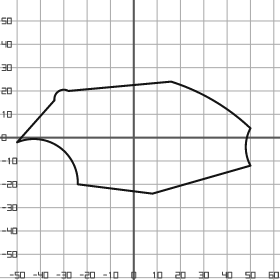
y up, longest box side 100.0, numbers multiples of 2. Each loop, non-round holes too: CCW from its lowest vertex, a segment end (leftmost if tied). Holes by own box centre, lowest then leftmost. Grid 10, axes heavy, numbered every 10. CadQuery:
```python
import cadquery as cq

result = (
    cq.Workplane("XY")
    .moveTo(8.0, -24.0)
    .lineTo(50.0, -12.0)
    .threePointArc((48.0, -4.0), (50.0, 4.0))
    .threePointArc((34.0, 16.0), (16.0, 24.0))
    .lineTo(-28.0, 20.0)
    .threePointArc((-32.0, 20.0), (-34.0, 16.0))
    .lineTo(-50.0, -2.0)
    .threePointArc((-32.0, -4.0), (-24.0, -20.0))
    .close()
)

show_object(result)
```